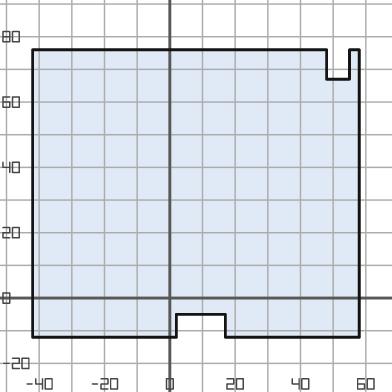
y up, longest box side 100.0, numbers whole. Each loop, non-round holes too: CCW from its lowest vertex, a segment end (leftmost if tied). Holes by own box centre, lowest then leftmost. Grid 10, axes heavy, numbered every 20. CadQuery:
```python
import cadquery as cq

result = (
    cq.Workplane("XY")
    .moveTo(-42.0, -12.0)
    .lineTo(2.0, -12.0)
    .lineTo(2.0, -5.0)
    .lineTo(17.0, -5.0)
    .lineTo(17.0, -12.0)
    .lineTo(58.0, -12.0)
    .lineTo(58.0, 76.0)
    .lineTo(55.0, 76.0)
    .lineTo(55.0, 67.0)
    .lineTo(48.0, 67.0)
    .lineTo(48.0, 76.0)
    .lineTo(-42.0, 76.0)
    .close()
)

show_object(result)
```